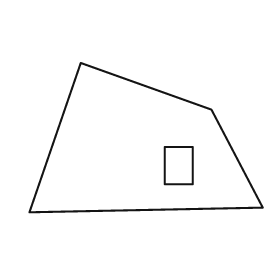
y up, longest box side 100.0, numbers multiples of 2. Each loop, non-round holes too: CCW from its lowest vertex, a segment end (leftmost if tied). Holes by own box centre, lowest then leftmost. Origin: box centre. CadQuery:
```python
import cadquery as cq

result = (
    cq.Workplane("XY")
    .moveTo(-50.0, -32.0)
    .lineTo(50.0, -30.0)
    .lineTo(28.0, 12.0)
    .lineTo(-28.0, 32.0)
    .close()
    .moveTo(8.0, -20.0)
    .lineTo(20.0, -20.0)
    .lineTo(20.0, -4.0)
    .lineTo(8.0, -4.0)
    .close()
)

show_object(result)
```